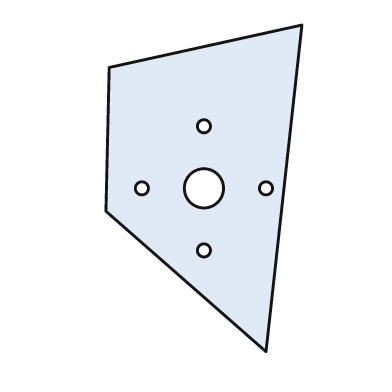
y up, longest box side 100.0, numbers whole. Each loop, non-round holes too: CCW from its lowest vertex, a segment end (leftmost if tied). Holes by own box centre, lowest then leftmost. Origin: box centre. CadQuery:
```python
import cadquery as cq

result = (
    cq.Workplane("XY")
    .moveTo(19.0, -50.0)
    .lineTo(30.0, 50.0)
    .lineTo(-29.0, 37.0)
    .lineTo(-30.0, -7.0)
    .close()
    .moveTo(0.0, -19.0)
    .circle(2.0)
    .moveTo(-19.0, 0.0)
    .circle(2.0)
    .moveTo(0.0, 0.0)
    .circle(6.0)
    .moveTo(19.0, 0.0)
    .circle(2.0)
    .moveTo(0.0, 19.0)
    .circle(2.0)
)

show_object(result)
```